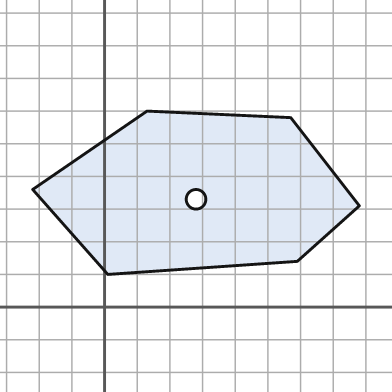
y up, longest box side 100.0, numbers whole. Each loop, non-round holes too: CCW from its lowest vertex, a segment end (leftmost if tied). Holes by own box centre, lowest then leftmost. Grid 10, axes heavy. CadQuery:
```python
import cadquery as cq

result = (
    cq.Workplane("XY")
    .moveTo(1.0, 10.0)
    .lineTo(59.0, 14.0)
    .lineTo(78.0, 31.0)
    .lineTo(57.0, 58.0)
    .lineTo(13.0, 60.0)
    .lineTo(-22.0, 36.0)
    .close()
    .moveTo(28.0, 33.0)
    .circle(3.0)
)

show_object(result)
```